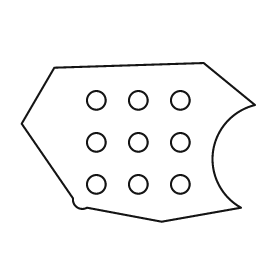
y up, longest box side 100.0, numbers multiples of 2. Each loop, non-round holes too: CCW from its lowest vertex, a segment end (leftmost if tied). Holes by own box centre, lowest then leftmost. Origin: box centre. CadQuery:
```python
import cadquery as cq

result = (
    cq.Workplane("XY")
    .moveTo(10.0, -34.0)
    .lineTo(44.0, -28.0)
    .threePointArc((32.0, -4.0), (50.0, 16.0))
    .lineTo(28.0, 34.0)
    .lineTo(-36.0, 32.0)
    .lineTo(-50.0, 8.0)
    .lineTo(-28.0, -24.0)
    .threePointArc((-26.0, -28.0), (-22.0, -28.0))
    .close()
    .moveTo(-18.0, -18.0)
    .circle(4.0)
    .moveTo(0.0, -18.0)
    .circle(4.0)
    .moveTo(18.0, -18.0)
    .circle(4.0)
    .moveTo(-18.0, 0.0)
    .circle(4.0)
    .moveTo(0.0, 0.0)
    .circle(4.0)
    .moveTo(18.0, 0.0)
    .circle(4.0)
    .moveTo(-18.0, 18.0)
    .circle(4.0)
    .moveTo(0.0, 18.0)
    .circle(4.0)
    .moveTo(18.0, 18.0)
    .circle(4.0)
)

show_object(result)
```